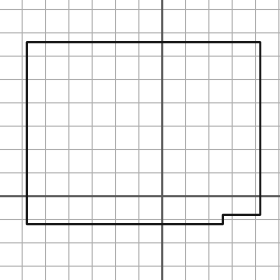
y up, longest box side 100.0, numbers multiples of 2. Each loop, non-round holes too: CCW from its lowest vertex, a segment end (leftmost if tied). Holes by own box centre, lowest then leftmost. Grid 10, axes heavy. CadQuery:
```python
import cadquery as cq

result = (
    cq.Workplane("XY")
    .moveTo(-58.0, -12.0)
    .lineTo(26.0, -12.0)
    .lineTo(26.0, -8.0)
    .lineTo(42.0, -8.0)
    .lineTo(42.0, 66.0)
    .lineTo(-58.0, 66.0)
    .close()
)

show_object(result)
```